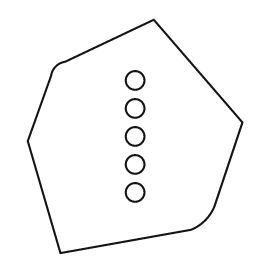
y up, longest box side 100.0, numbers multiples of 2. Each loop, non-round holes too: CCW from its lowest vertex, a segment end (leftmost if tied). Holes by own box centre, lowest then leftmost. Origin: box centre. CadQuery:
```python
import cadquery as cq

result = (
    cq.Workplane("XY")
    .moveTo(-32.0, -50.0)
    .lineTo(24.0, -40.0)
    .threePointArc((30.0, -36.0), (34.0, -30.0))
    .lineTo(46.0, 6.0)
    .lineTo(8.0, 50.0)
    .lineTo(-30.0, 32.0)
    .threePointArc((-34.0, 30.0), (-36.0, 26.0))
    .lineTo(-46.0, -2.0)
    .close()
    .moveTo(0.0, -24.0)
    .circle(4.0)
    .moveTo(0.0, -12.0)
    .circle(4.0)
    .moveTo(0.0, 0.0)
    .circle(4.0)
    .moveTo(0.0, 12.0)
    .circle(4.0)
    .moveTo(0.0, 24.0)
    .circle(4.0)
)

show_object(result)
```